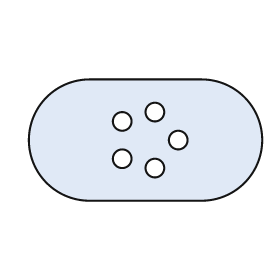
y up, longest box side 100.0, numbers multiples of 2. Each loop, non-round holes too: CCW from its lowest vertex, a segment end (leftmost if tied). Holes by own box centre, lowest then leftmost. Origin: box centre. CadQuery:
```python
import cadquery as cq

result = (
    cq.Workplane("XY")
    .moveTo(-24.0, -26.0)
    .lineTo(24.0, -26.0)
    .threePointArc((50.0, 0.0), (24.0, 26.0))
    .lineTo(-24.0, 26.0)
    .threePointArc((-50.0, 0.0), (-24.0, -26.0))
    .close()
    .moveTo(4.0, -12.0)
    .circle(4.0)
    .moveTo(-10.0, -8.0)
    .circle(4.0)
    .moveTo(14.0, 0.0)
    .circle(4.0)
    .moveTo(-10.0, 8.0)
    .circle(4.0)
    .moveTo(4.0, 12.0)
    .circle(4.0)
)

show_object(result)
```